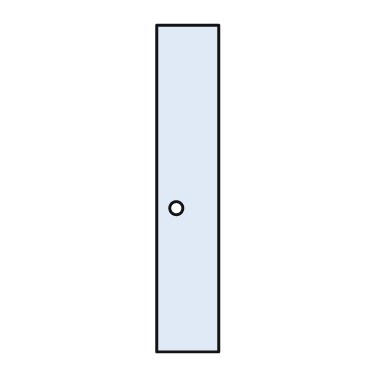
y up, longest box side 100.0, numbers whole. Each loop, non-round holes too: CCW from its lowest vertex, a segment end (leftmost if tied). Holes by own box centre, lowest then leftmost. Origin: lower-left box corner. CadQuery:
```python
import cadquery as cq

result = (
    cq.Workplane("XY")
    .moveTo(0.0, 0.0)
    .lineTo(19.0, 0.0)
    .lineTo(19.0, 100.0)
    .lineTo(0.0, 100.0)
    .close()
    .moveTo(6.0, 44.0)
    .circle(2.0)
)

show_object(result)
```